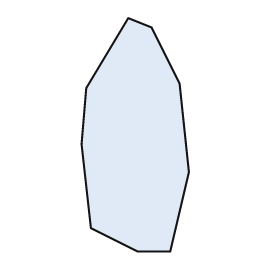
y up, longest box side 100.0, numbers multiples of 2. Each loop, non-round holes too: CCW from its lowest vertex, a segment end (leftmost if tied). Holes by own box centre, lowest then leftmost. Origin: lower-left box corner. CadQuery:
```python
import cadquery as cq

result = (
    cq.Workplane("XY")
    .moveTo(24.0, 0.0)
    .lineTo(38.0, 0.0)
    .lineTo(46.0, 34.0)
    .lineTo(42.0, 72.0)
    .lineTo(30.0, 96.0)
    .lineTo(20.0, 100.0)
    .lineTo(2.0, 70.0)
    .lineTo(0.0, 46.0)
    .lineTo(4.0, 10.0)
    .close()
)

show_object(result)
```